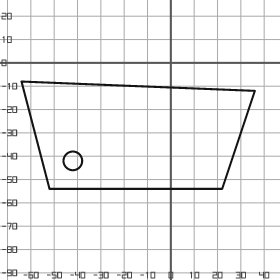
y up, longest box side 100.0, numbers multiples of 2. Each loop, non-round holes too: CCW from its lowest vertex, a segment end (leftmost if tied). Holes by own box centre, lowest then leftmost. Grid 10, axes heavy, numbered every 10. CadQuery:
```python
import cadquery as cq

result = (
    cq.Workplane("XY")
    .moveTo(-52.0, -54.0)
    .lineTo(22.0, -54.0)
    .lineTo(36.0, -12.0)
    .lineTo(-64.0, -8.0)
    .close()
    .moveTo(-42.0, -42.0)
    .circle(4.0)
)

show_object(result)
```